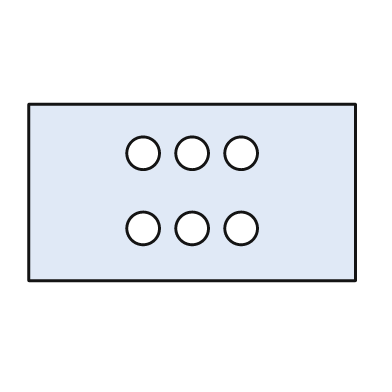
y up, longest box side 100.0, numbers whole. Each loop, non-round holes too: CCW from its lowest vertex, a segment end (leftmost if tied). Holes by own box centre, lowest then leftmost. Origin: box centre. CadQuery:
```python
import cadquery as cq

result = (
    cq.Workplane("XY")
    .moveTo(-50.0, -27.0)
    .lineTo(50.0, -27.0)
    .lineTo(50.0, 27.0)
    .lineTo(-50.0, 27.0)
    .close()
    .moveTo(-15.0, -11.0)
    .circle(5.0)
    .moveTo(0.0, -11.0)
    .circle(5.0)
    .moveTo(15.0, -11.0)
    .circle(5.0)
    .moveTo(-15.0, 12.0)
    .circle(5.0)
    .moveTo(0.0, 12.0)
    .circle(5.0)
    .moveTo(15.0, 12.0)
    .circle(5.0)
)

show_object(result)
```